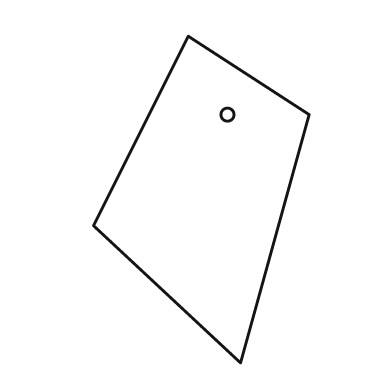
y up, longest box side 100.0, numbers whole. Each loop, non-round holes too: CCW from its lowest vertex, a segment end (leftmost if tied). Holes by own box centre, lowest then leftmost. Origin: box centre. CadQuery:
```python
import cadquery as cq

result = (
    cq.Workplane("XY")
    .moveTo(12.0, -50.0)
    .lineTo(33.0, 26.0)
    .lineTo(-4.0, 50.0)
    .lineTo(-33.0, -8.0)
    .close()
    .moveTo(8.0, 26.0)
    .circle(2.0)
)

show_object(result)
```